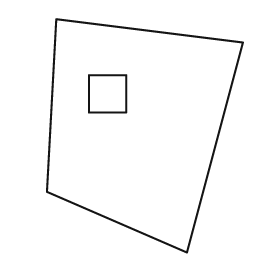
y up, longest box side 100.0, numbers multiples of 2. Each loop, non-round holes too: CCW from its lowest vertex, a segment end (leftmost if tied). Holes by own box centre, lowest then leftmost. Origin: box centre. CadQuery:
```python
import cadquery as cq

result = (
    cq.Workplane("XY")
    .moveTo(18.0, -50.0)
    .lineTo(42.0, 40.0)
    .lineTo(-38.0, 50.0)
    .lineTo(-42.0, -24.0)
    .close()
    .moveTo(-24.0, 10.0)
    .lineTo(-8.0, 10.0)
    .lineTo(-8.0, 26.0)
    .lineTo(-24.0, 26.0)
    .close()
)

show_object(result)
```